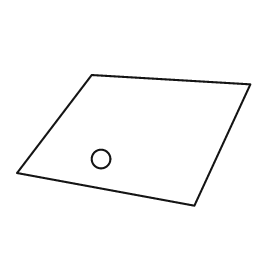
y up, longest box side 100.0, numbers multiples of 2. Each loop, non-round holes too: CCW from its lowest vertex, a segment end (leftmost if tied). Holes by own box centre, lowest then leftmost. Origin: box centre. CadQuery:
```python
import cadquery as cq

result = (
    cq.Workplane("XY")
    .moveTo(26.0, -28.0)
    .lineTo(50.0, 24.0)
    .lineTo(-18.0, 28.0)
    .lineTo(-50.0, -14.0)
    .close()
    .moveTo(-14.0, -8.0)
    .circle(4.0)
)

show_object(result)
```